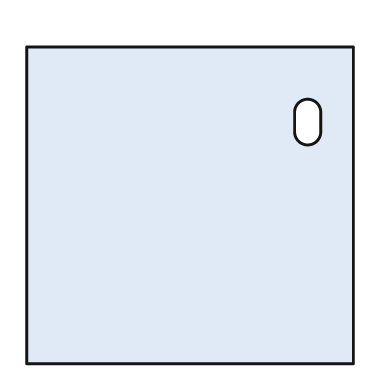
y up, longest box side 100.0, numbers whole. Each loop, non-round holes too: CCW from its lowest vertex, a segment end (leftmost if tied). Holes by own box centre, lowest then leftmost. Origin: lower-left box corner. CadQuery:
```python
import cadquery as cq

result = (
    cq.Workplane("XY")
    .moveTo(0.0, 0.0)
    .lineTo(100.0, 0.0)
    .lineTo(100.0, 97.0)
    .lineTo(0.0, 97.0)
    .close()
    .moveTo(82.0, 71.0)
    .threePointArc((86.0, 67.0), (90.0, 71.0))
    .lineTo(90.0, 77.0)
    .threePointArc((86.0, 81.0), (82.0, 77.0))
    .close()
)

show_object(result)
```